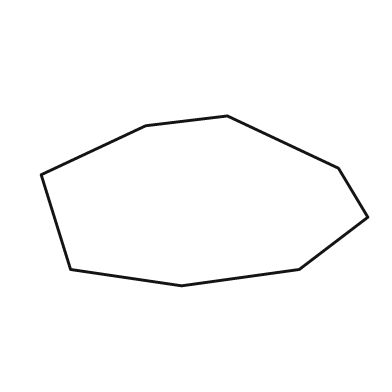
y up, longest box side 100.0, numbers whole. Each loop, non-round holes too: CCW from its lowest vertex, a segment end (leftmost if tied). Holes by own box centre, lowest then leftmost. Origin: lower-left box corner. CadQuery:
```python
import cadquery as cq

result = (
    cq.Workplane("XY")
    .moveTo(43.0, 0.0)
    .lineTo(79.0, 5.0)
    .lineTo(100.0, 21.0)
    .lineTo(91.0, 36.0)
    .lineTo(57.0, 52.0)
    .lineTo(32.0, 49.0)
    .lineTo(0.0, 34.0)
    .lineTo(9.0, 5.0)
    .close()
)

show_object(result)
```